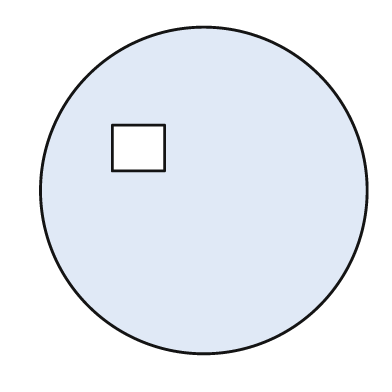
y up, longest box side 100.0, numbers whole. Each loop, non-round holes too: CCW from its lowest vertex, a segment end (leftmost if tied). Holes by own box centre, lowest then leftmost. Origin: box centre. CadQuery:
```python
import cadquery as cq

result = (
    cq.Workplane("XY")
    .moveTo(0.0, 0.0)
    .circle(50.0)
    .moveTo(-28.0, 6.0)
    .lineTo(-12.0, 6.0)
    .lineTo(-12.0, 20.0)
    .lineTo(-28.0, 20.0)
    .close()
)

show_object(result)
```